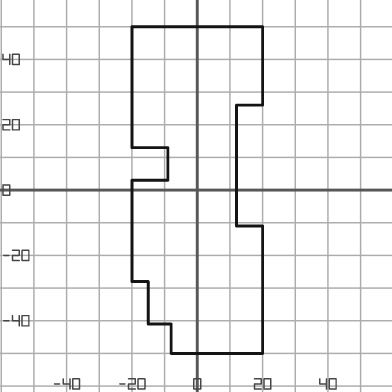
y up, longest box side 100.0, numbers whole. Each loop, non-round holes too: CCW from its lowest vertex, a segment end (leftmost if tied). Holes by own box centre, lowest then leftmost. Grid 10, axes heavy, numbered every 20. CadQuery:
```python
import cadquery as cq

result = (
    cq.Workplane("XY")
    .moveTo(-8.0, -50.0)
    .lineTo(20.0, -50.0)
    .lineTo(20.0, -11.0)
    .lineTo(12.0, -11.0)
    .lineTo(12.0, 26.0)
    .lineTo(20.0, 26.0)
    .lineTo(20.0, 50.0)
    .lineTo(-20.0, 50.0)
    .lineTo(-20.0, 13.0)
    .lineTo(-9.0, 13.0)
    .lineTo(-9.0, 3.0)
    .lineTo(-20.0, 3.0)
    .lineTo(-20.0, -28.0)
    .lineTo(-15.0, -28.0)
    .lineTo(-15.0, -41.0)
    .lineTo(-8.0, -41.0)
    .close()
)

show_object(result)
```